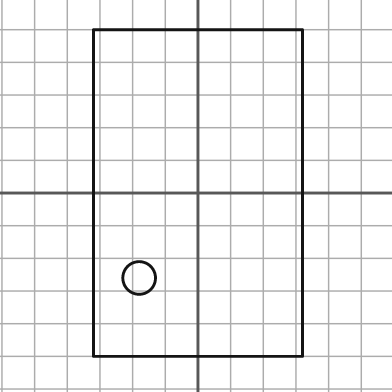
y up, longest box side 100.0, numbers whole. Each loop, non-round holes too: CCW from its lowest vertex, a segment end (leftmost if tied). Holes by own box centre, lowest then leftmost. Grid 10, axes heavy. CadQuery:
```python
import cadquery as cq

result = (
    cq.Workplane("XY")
    .moveTo(-32.0, -50.0)
    .lineTo(32.0, -50.0)
    .lineTo(32.0, 50.0)
    .lineTo(-32.0, 50.0)
    .close()
    .moveTo(-18.0, -26.0)
    .circle(5.0)
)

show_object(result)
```